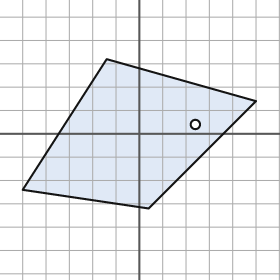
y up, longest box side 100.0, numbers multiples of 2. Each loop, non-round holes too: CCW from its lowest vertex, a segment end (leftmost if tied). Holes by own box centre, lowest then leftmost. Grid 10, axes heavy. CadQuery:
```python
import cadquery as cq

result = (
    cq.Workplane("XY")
    .moveTo(4.0, -32.0)
    .lineTo(50.0, 14.0)
    .lineTo(-14.0, 32.0)
    .lineTo(-50.0, -24.0)
    .close()
    .moveTo(24.0, 4.0)
    .circle(2.0)
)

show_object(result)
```